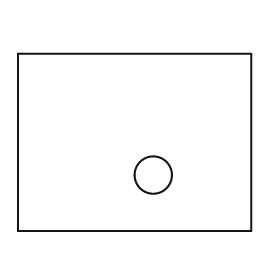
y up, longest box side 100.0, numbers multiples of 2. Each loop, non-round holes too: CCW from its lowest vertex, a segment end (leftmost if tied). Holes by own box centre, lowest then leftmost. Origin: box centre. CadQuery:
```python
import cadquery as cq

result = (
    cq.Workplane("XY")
    .moveTo(-50.0, -38.0)
    .lineTo(50.0, -38.0)
    .lineTo(50.0, 38.0)
    .lineTo(-50.0, 38.0)
    .close()
    .moveTo(8.0, -14.0)
    .circle(8.0)
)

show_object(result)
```